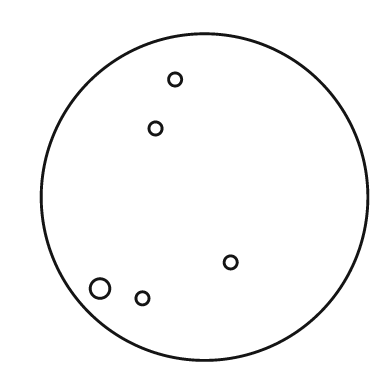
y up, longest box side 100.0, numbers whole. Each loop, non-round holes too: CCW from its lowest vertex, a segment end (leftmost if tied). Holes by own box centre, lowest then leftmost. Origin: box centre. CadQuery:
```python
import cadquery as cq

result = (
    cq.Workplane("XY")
    .moveTo(0.0, 0.0)
    .circle(50.0)
    .moveTo(-19.0, -31.0)
    .circle(2.0)
    .moveTo(-32.0, -28.0)
    .circle(3.0)
    .moveTo(8.0, -20.0)
    .circle(2.0)
    .moveTo(-15.0, 21.0)
    .circle(2.0)
    .moveTo(-9.0, 36.0)
    .circle(2.0)
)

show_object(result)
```